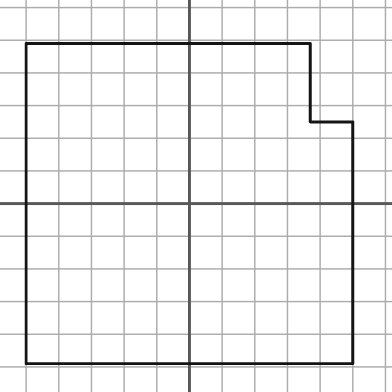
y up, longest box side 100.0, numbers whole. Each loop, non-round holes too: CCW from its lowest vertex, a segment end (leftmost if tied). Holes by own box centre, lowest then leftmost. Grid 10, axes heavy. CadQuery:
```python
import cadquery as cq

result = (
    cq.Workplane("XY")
    .moveTo(-50.0, -49.0)
    .lineTo(50.0, -49.0)
    .lineTo(50.0, 25.0)
    .lineTo(37.0, 25.0)
    .lineTo(37.0, 49.0)
    .lineTo(-50.0, 49.0)
    .close()
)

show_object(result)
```